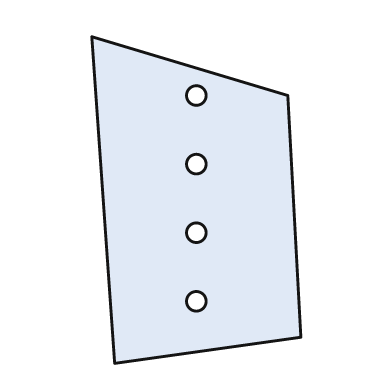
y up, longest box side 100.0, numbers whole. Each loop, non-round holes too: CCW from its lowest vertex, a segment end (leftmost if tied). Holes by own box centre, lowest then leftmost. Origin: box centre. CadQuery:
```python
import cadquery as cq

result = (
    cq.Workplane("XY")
    .moveTo(-25.0, -50.0)
    .lineTo(32.0, -42.0)
    .lineTo(28.0, 32.0)
    .lineTo(-32.0, 50.0)
    .close()
    .moveTo(0.0, -31.0)
    .circle(3.0)
    .moveTo(0.0, -10.0)
    .circle(3.0)
    .moveTo(0.0, 11.0)
    .circle(3.0)
    .moveTo(0.0, 32.0)
    .circle(3.0)
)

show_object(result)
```